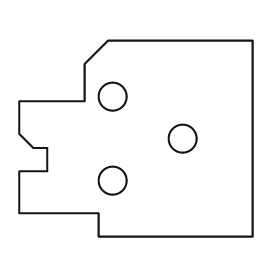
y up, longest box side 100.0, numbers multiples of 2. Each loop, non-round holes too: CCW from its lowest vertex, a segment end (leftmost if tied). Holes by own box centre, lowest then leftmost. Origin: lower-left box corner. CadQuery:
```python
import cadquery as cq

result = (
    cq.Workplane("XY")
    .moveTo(34.0, 0.0)
    .lineTo(100.0, 0.0)
    .lineTo(100.0, 84.0)
    .lineTo(38.0, 84.0)
    .lineTo(28.0, 74.0)
    .lineTo(28.0, 58.0)
    .lineTo(0.0, 58.0)
    .lineTo(0.0, 44.0)
    .lineTo(6.0, 38.0)
    .lineTo(12.0, 38.0)
    .lineTo(12.0, 28.0)
    .lineTo(0.0, 28.0)
    .lineTo(0.0, 10.0)
    .lineTo(34.0, 10.0)
    .close()
    .moveTo(40.0, 24.0)
    .circle(6.0)
    .moveTo(70.0, 42.0)
    .circle(6.0)
    .moveTo(40.0, 60.0)
    .circle(6.0)
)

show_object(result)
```